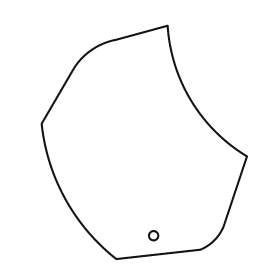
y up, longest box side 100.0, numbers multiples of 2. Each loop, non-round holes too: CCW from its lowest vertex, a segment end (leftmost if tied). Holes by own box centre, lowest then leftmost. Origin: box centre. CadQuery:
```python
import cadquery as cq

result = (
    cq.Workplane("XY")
    .moveTo(-12.0, -50.0)
    .lineTo(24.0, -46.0)
    .threePointArc((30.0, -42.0), (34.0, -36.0))
    .lineTo(44.0, -6.0)
    .threePointArc((20.0, 18.0), (10.0, 50.0))
    .lineTo(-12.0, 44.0)
    .threePointArc((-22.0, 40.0), (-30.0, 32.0))
    .lineTo(-44.0, 8.0)
    .threePointArc((-34.0, -24.0), (-12.0, -50.0))
    .close()
    .moveTo(4.0, -40.0)
    .circle(2.0)
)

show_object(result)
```